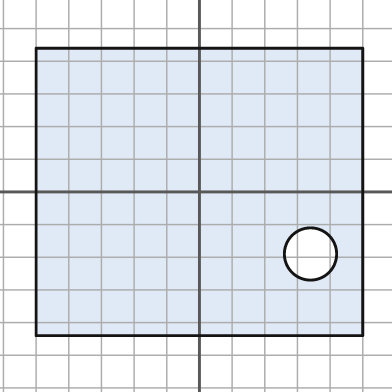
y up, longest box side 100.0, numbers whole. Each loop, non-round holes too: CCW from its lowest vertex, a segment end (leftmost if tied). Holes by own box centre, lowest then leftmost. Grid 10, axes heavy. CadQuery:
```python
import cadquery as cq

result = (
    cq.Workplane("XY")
    .moveTo(-50.0, -44.0)
    .lineTo(50.0, -44.0)
    .lineTo(50.0, 44.0)
    .lineTo(-50.0, 44.0)
    .close()
    .moveTo(34.0, -19.0)
    .circle(8.0)
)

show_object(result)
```